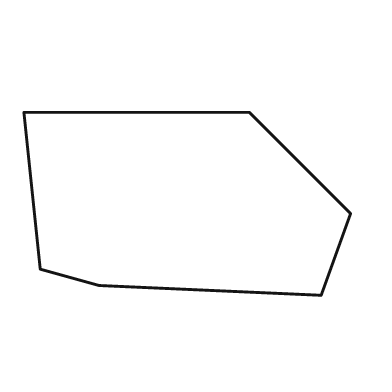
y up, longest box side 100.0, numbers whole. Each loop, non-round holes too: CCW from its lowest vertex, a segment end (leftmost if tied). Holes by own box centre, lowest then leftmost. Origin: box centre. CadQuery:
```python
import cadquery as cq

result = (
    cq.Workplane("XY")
    .moveTo(41.0, -28.0)
    .lineTo(50.0, -3.0)
    .lineTo(19.0, 28.0)
    .lineTo(-50.0, 28.0)
    .lineTo(-45.0, -20.0)
    .lineTo(-27.0, -25.0)
    .close()
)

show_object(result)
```